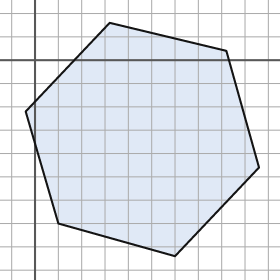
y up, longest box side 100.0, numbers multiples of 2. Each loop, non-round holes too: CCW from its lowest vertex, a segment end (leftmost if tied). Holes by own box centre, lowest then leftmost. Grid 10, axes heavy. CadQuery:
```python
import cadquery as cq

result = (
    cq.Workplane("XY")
    .moveTo(60.0, -84.0)
    .lineTo(96.0, -46.0)
    .lineTo(82.0, 4.0)
    .lineTo(32.0, 16.0)
    .lineTo(-4.0, -22.0)
    .lineTo(10.0, -70.0)
    .close()
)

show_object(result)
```